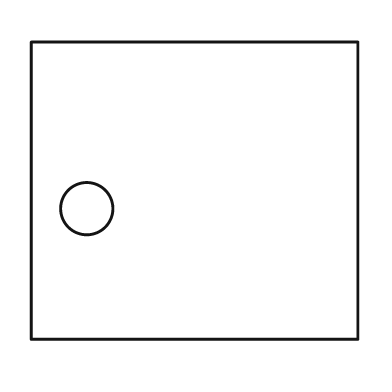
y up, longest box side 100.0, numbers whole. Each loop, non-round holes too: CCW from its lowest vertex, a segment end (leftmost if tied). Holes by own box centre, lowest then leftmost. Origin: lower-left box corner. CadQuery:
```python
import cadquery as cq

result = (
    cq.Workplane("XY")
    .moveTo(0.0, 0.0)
    .lineTo(100.0, 0.0)
    .lineTo(100.0, 91.0)
    .lineTo(0.0, 91.0)
    .close()
    .moveTo(17.0, 40.0)
    .circle(8.0)
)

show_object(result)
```